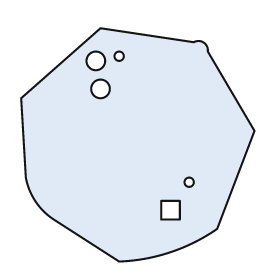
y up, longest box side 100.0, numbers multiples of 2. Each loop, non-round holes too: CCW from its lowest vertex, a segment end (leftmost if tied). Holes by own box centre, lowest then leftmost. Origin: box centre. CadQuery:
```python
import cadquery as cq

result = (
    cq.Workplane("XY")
    .moveTo(-8.0, -50.0)
    .threePointArc((14.0, -46.0), (34.0, -36.0))
    .lineTo(50.0, 6.0)
    .lineTo(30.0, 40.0)
    .threePointArc((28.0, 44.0), (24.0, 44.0))
    .lineTo(-16.0, 50.0)
    .lineTo(-50.0, 20.0)
    .lineTo(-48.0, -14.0)
    .threePointArc((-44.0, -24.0), (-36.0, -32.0))
    .close()
    .moveTo(10.0, -32.0)
    .lineTo(18.0, -32.0)
    .lineTo(18.0, -24.0)
    .lineTo(10.0, -24.0)
    .close()
    .moveTo(22.0, -16.0)
    .circle(2.0)
    .moveTo(-16.0, 24.0)
    .circle(4.0)
    .moveTo(-18.0, 36.0)
    .circle(4.0)
    .moveTo(-8.0, 38.0)
    .circle(2.0)
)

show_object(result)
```